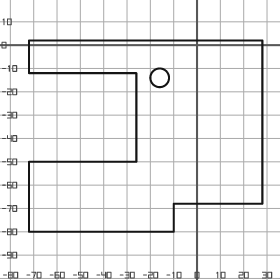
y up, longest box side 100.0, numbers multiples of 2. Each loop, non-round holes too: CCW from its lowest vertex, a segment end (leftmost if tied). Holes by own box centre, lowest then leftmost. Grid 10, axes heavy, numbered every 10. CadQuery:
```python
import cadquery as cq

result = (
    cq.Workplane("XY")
    .moveTo(-72.0, -80.0)
    .lineTo(-10.0, -80.0)
    .lineTo(-10.0, -68.0)
    .lineTo(28.0, -68.0)
    .lineTo(28.0, 2.0)
    .lineTo(-72.0, 2.0)
    .lineTo(-72.0, -12.0)
    .lineTo(-26.0, -12.0)
    .lineTo(-26.0, -50.0)
    .lineTo(-72.0, -50.0)
    .close()
    .moveTo(-16.0, -14.0)
    .circle(4.0)
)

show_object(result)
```